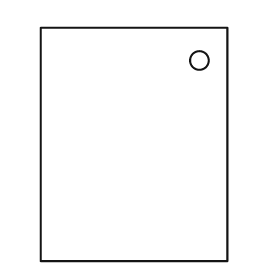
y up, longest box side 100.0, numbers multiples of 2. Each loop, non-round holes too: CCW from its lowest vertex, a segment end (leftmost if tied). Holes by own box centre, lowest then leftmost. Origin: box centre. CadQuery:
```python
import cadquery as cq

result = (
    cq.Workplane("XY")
    .moveTo(-40.0, -50.0)
    .lineTo(40.0, -50.0)
    .lineTo(40.0, 50.0)
    .lineTo(-40.0, 50.0)
    .close()
    .moveTo(28.0, 36.0)
    .circle(4.0)
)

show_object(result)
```